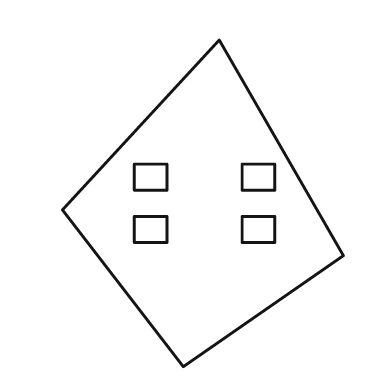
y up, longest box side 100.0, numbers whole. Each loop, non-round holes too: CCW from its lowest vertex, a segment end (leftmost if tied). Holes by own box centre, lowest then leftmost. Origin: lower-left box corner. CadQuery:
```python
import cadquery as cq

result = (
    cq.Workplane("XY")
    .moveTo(37.0, 0.0)
    .lineTo(86.0, 34.0)
    .lineTo(48.0, 100.0)
    .lineTo(0.0, 48.0)
    .close()
    .moveTo(22.0, 38.0)
    .lineTo(32.0, 38.0)
    .lineTo(32.0, 46.0)
    .lineTo(22.0, 46.0)
    .close()
    .moveTo(55.0, 38.0)
    .lineTo(65.0, 38.0)
    .lineTo(65.0, 46.0)
    .lineTo(55.0, 46.0)
    .close()
    .moveTo(22.0, 54.0)
    .lineTo(32.0, 54.0)
    .lineTo(32.0, 62.0)
    .lineTo(22.0, 62.0)
    .close()
    .moveTo(55.0, 54.0)
    .lineTo(65.0, 54.0)
    .lineTo(65.0, 62.0)
    .lineTo(55.0, 62.0)
    .close()
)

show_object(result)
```